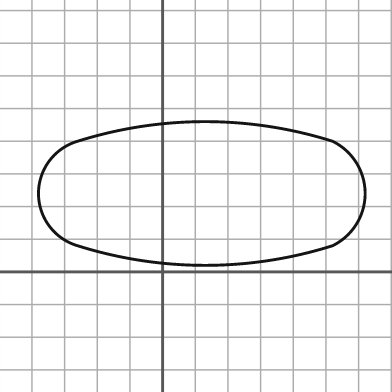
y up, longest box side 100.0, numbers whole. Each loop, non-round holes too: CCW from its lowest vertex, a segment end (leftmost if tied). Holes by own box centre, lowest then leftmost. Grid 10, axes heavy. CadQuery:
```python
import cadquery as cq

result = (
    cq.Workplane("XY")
    .moveTo(-26.0, 8.0)
    .threePointArc((13.0, 2.0), (52.0, 8.0))
    .threePointArc((62.0, 24.0), (52.0, 40.0))
    .threePointArc((13.0, 46.0), (-26.0, 40.0))
    .threePointArc((-38.0, 24.0), (-26.0, 8.0))
    .close()
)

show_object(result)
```